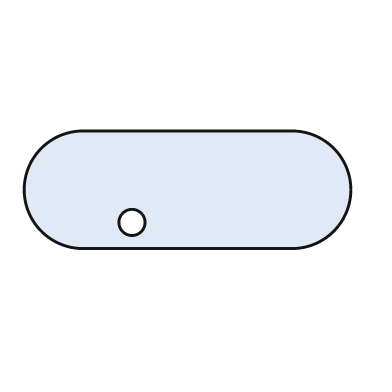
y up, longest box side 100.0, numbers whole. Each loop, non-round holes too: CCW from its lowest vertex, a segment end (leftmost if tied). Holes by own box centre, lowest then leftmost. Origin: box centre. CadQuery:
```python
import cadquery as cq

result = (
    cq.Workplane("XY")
    .moveTo(-32.0, -18.0)
    .lineTo(32.0, -18.0)
    .threePointArc((50.0, 0.0), (32.0, 18.0))
    .lineTo(-32.0, 18.0)
    .threePointArc((-50.0, 0.0), (-32.0, -18.0))
    .close()
    .moveTo(-17.0, -10.0)
    .circle(4.0)
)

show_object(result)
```